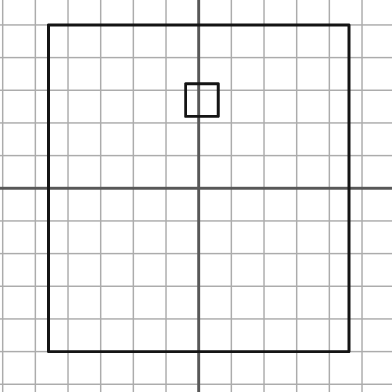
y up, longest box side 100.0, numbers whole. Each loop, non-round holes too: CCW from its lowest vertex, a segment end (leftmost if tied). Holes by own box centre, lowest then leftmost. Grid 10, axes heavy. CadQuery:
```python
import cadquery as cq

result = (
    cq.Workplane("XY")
    .moveTo(-46.0, -50.0)
    .lineTo(46.0, -50.0)
    .lineTo(46.0, 50.0)
    .lineTo(-46.0, 50.0)
    .close()
    .moveTo(-4.0, 22.0)
    .lineTo(6.0, 22.0)
    .lineTo(6.0, 32.0)
    .lineTo(-4.0, 32.0)
    .close()
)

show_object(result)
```